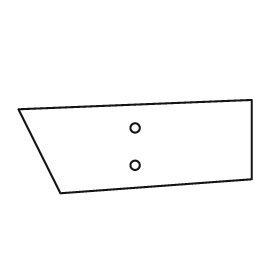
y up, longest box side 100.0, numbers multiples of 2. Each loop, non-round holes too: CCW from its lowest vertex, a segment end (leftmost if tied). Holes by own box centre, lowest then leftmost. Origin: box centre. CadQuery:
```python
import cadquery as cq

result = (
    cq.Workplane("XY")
    .moveTo(-32.0, -20.0)
    .lineTo(50.0, -14.0)
    .lineTo(50.0, 20.0)
    .lineTo(-50.0, 16.0)
    .close()
    .moveTo(0.0, -8.0)
    .circle(2.0)
    .moveTo(0.0, 8.0)
    .circle(2.0)
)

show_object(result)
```